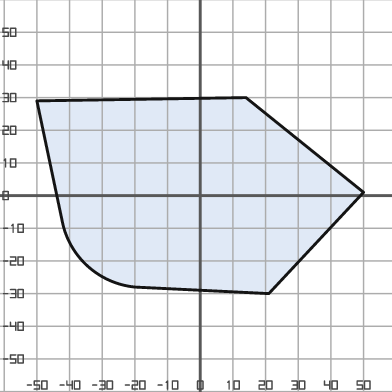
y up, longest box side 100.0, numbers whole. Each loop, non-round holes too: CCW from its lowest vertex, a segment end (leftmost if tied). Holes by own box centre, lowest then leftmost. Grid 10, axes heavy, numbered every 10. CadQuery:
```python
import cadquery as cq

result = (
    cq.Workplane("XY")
    .moveTo(21.0, -30.0)
    .lineTo(50.0, 1.0)
    .lineTo(14.0, 30.0)
    .lineTo(-50.0, 29.0)
    .lineTo(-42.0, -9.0)
    .threePointArc((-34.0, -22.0), (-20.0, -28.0))
    .close()
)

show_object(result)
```